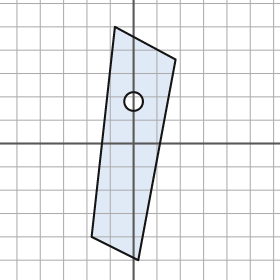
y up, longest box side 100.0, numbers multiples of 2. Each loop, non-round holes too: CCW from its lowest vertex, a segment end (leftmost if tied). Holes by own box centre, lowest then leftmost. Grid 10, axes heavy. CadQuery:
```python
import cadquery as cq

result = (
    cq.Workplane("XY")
    .moveTo(2.0, -50.0)
    .lineTo(18.0, 36.0)
    .lineTo(-8.0, 50.0)
    .lineTo(-18.0, -40.0)
    .close()
    .moveTo(0.0, 18.0)
    .circle(4.0)
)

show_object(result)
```